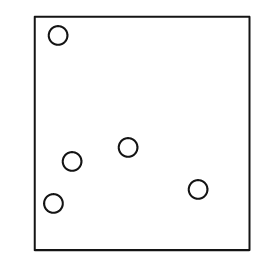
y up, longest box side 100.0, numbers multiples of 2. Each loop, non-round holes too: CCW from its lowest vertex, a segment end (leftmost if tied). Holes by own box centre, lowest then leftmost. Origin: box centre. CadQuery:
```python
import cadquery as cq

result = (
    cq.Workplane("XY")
    .moveTo(-46.0, -50.0)
    .lineTo(46.0, -50.0)
    .lineTo(46.0, 50.0)
    .lineTo(-46.0, 50.0)
    .close()
    .moveTo(-38.0, -30.0)
    .circle(4.0)
    .moveTo(24.0, -24.0)
    .circle(4.0)
    .moveTo(-30.0, -12.0)
    .circle(4.0)
    .moveTo(-6.0, -6.0)
    .circle(4.0)
    .moveTo(-36.0, 42.0)
    .circle(4.0)
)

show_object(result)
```